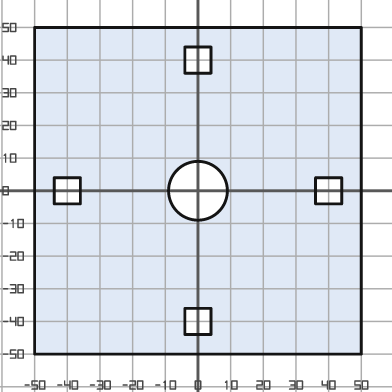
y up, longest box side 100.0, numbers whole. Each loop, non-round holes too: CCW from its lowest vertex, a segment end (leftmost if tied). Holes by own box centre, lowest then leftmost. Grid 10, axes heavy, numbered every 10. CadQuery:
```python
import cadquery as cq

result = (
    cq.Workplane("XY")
    .moveTo(-50.0, -50.0)
    .lineTo(50.0, -50.0)
    .lineTo(50.0, 50.0)
    .lineTo(-50.0, 50.0)
    .close()
    .moveTo(-4.0, -44.0)
    .lineTo(4.0, -44.0)
    .lineTo(4.0, -36.0)
    .lineTo(-4.0, -36.0)
    .close()
    .moveTo(-44.0, -4.0)
    .lineTo(-36.0, -4.0)
    .lineTo(-36.0, 4.0)
    .lineTo(-44.0, 4.0)
    .close()
    .moveTo(0.0, 0.0)
    .circle(9.0)
    .moveTo(36.0, -4.0)
    .lineTo(44.0, -4.0)
    .lineTo(44.0, 4.0)
    .lineTo(36.0, 4.0)
    .close()
    .moveTo(-4.0, 36.0)
    .lineTo(4.0, 36.0)
    .lineTo(4.0, 44.0)
    .lineTo(-4.0, 44.0)
    .close()
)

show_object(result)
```